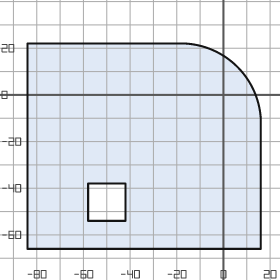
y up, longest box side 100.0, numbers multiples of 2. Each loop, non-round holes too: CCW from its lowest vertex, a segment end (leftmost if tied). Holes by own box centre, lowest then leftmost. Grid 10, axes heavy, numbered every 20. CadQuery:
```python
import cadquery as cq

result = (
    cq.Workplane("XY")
    .moveTo(-84.0, -66.0)
    .lineTo(16.0, -66.0)
    .lineTo(16.0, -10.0)
    .threePointArc((6.0, 12.0), (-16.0, 22.0))
    .lineTo(-84.0, 22.0)
    .close()
    .moveTo(-58.0, -54.0)
    .lineTo(-42.0, -54.0)
    .lineTo(-42.0, -38.0)
    .lineTo(-58.0, -38.0)
    .close()
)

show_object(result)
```